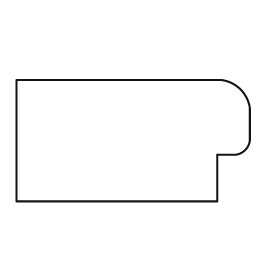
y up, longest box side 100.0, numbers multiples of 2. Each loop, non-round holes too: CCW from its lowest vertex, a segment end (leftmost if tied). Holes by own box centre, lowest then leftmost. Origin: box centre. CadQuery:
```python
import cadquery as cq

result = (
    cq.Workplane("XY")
    .moveTo(-50.0, -26.0)
    .lineTo(36.0, -26.0)
    .lineTo(36.0, -6.0)
    .lineTo(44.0, -6.0)
    .threePointArc((48.0, -4.0), (50.0, 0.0))
    .lineTo(50.0, 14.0)
    .threePointArc((46.0, 22.0), (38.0, 26.0))
    .lineTo(-50.0, 26.0)
    .close()
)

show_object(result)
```